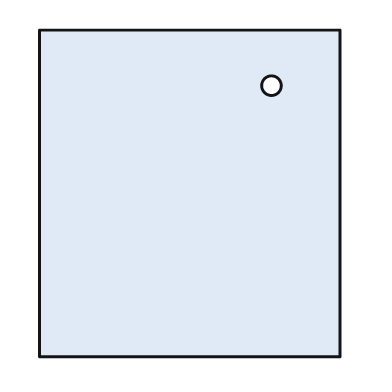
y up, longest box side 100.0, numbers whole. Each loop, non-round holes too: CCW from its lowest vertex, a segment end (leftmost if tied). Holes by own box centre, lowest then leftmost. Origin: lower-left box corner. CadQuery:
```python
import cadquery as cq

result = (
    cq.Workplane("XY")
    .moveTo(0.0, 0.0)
    .lineTo(92.0, 0.0)
    .lineTo(92.0, 100.0)
    .lineTo(0.0, 100.0)
    .close()
    .moveTo(71.0, 83.0)
    .circle(3.0)
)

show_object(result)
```